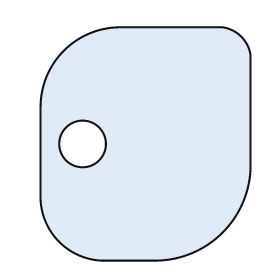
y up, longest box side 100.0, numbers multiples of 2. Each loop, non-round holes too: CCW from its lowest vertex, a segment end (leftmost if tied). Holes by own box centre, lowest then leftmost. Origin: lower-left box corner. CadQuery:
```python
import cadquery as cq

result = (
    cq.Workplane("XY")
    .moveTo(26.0, 0.0)
    .lineTo(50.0, 0.0)
    .threePointArc((78.0, 12.0), (90.0, 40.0))
    .lineTo(90.0, 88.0)
    .threePointArc((86.0, 96.0), (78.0, 100.0))
    .lineTo(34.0, 100.0)
    .threePointArc((10.0, 90.0), (0.0, 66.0))
    .lineTo(0.0, 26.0)
    .threePointArc((8.0, 8.0), (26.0, 0.0))
    .close()
    .moveTo(18.0, 50.0)
    .circle(10.0)
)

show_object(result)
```